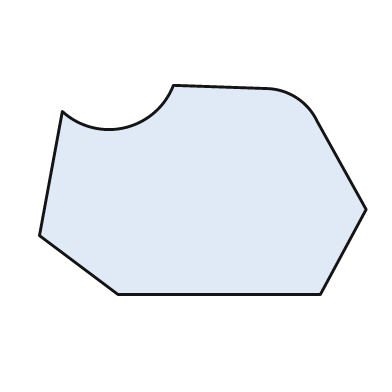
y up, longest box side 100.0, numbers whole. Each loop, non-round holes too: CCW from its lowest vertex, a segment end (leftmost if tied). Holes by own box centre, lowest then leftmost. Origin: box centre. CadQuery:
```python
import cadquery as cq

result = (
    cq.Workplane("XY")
    .moveTo(-26.0, -32.0)
    .lineTo(36.0, -32.0)
    .lineTo(50.0, -6.0)
    .lineTo(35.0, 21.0)
    .threePointArc((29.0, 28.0), (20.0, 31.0))
    .lineTo(-9.0, 32.0)
    .threePointArc((-24.0, 19.0), (-43.0, 24.0))
    .lineTo(-50.0, -14.0)
    .close()
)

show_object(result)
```